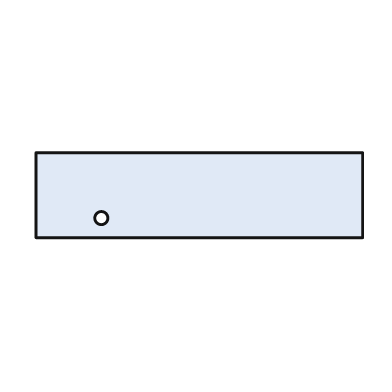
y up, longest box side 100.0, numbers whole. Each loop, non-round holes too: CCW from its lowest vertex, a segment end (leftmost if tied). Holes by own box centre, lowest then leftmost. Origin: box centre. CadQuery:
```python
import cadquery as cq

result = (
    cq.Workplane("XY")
    .moveTo(-50.0, -13.0)
    .lineTo(50.0, -13.0)
    .lineTo(50.0, 13.0)
    .lineTo(-50.0, 13.0)
    .close()
    .moveTo(-30.0, -7.0)
    .circle(2.0)
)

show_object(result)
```